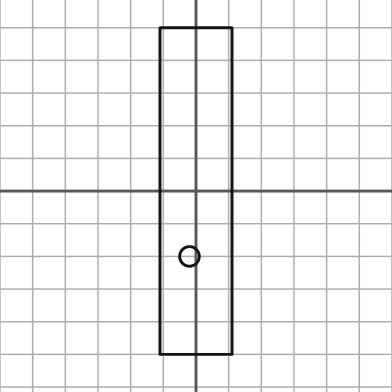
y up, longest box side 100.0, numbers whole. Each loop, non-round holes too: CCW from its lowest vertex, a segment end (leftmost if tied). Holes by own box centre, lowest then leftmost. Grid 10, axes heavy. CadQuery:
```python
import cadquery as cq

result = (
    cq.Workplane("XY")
    .moveTo(-11.0, -50.0)
    .lineTo(11.0, -50.0)
    .lineTo(11.0, 50.0)
    .lineTo(-11.0, 50.0)
    .close()
    .moveTo(-2.0, -20.0)
    .circle(3.0)
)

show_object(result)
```